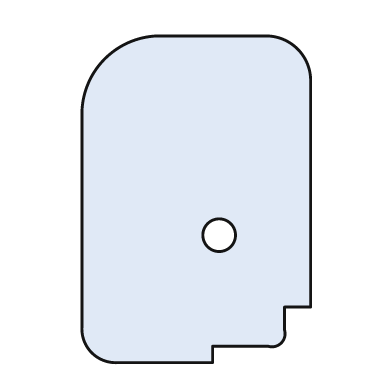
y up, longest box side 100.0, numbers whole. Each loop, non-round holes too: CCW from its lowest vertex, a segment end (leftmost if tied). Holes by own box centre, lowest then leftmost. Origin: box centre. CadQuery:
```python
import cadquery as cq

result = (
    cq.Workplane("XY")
    .moveTo(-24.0, -50.0)
    .lineTo(5.0, -50.0)
    .lineTo(5.0, -45.0)
    .lineTo(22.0, -45.0)
    .threePointArc((26.0, -44.0), (27.0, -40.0))
    .lineTo(27.0, -33.0)
    .lineTo(35.0, -33.0)
    .lineTo(35.0, 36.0)
    .threePointArc((31.0, 46.0), (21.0, 50.0))
    .lineTo(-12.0, 50.0)
    .threePointArc((-28.0, 43.0), (-35.0, 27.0))
    .lineTo(-35.0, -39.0)
    .threePointArc((-32.0, -47.0), (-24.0, -50.0))
    .close()
    .moveTo(7.0, -11.0)
    .circle(5.0)
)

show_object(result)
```